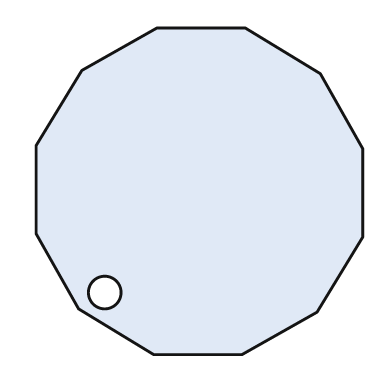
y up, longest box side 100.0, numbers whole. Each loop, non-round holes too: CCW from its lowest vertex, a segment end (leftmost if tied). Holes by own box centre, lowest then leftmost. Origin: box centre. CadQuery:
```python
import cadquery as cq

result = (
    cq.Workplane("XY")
    .moveTo(-14.0, -50.0)
    .lineTo(13.0, -50.0)
    .lineTo(36.0, -37.0)
    .lineTo(50.0, -14.0)
    .lineTo(50.0, 13.0)
    .lineTo(37.0, 36.0)
    .lineTo(14.0, 50.0)
    .lineTo(-13.0, 50.0)
    .lineTo(-36.0, 37.0)
    .lineTo(-50.0, 14.0)
    .lineTo(-50.0, -13.0)
    .lineTo(-37.0, -36.0)
    .close()
    .moveTo(-29.0, -31.0)
    .circle(5.0)
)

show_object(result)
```